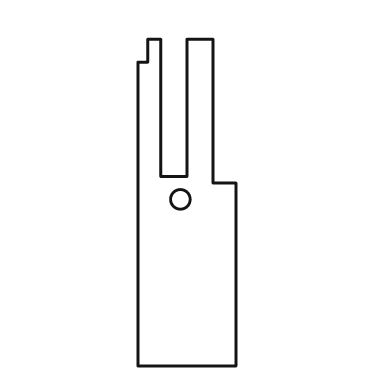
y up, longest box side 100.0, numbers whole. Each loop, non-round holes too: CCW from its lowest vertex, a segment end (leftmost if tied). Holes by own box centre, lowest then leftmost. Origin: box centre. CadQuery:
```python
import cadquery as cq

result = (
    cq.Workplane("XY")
    .moveTo(-15.0, -50.0)
    .lineTo(15.0, -50.0)
    .lineTo(15.0, 6.0)
    .lineTo(8.0, 6.0)
    .lineTo(8.0, 50.0)
    .lineTo(0.0, 50.0)
    .lineTo(0.0, 8.0)
    .lineTo(-8.0, 8.0)
    .lineTo(-8.0, 50.0)
    .lineTo(-12.0, 50.0)
    .lineTo(-12.0, 43.0)
    .lineTo(-15.0, 43.0)
    .close()
    .moveTo(-2.0, 1.0)
    .circle(3.0)
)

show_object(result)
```